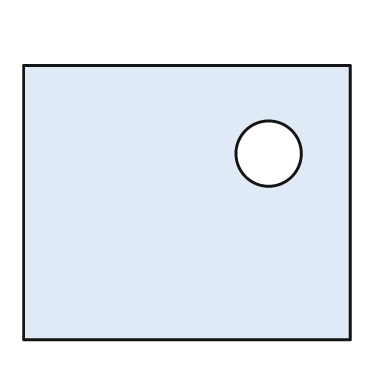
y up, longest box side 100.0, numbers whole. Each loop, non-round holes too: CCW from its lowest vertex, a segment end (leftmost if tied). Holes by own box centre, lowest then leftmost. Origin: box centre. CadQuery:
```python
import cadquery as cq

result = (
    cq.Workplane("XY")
    .moveTo(-50.0, -42.0)
    .lineTo(50.0, -42.0)
    .lineTo(50.0, 42.0)
    .lineTo(-50.0, 42.0)
    .close()
    .moveTo(25.0, 15.0)
    .circle(10.0)
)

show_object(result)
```